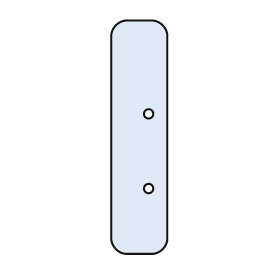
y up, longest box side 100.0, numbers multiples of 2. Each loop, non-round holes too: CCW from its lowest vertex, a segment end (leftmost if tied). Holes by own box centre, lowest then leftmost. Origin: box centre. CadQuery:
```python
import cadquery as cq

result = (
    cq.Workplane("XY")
    .moveTo(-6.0, -50.0)
    .lineTo(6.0, -50.0)
    .threePointArc((10.0, -48.0), (12.0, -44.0))
    .lineTo(12.0, 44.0)
    .threePointArc((10.0, 48.0), (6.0, 50.0))
    .lineTo(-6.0, 50.0)
    .threePointArc((-10.0, 48.0), (-12.0, 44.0))
    .lineTo(-12.0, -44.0)
    .threePointArc((-10.0, -48.0), (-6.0, -50.0))
    .close()
    .moveTo(4.0, -22.0)
    .circle(2.0)
    .moveTo(4.0, 10.0)
    .circle(2.0)
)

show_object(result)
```